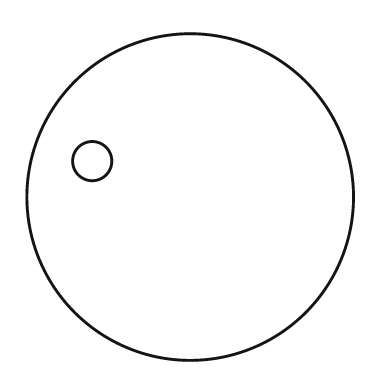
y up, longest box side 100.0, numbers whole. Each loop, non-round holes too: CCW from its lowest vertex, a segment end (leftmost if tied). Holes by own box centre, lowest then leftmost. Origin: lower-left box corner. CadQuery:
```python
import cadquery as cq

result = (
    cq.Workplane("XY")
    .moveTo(50.0, 50.0)
    .circle(50.0)
    .moveTo(20.0, 61.0)
    .circle(6.0)
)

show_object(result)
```